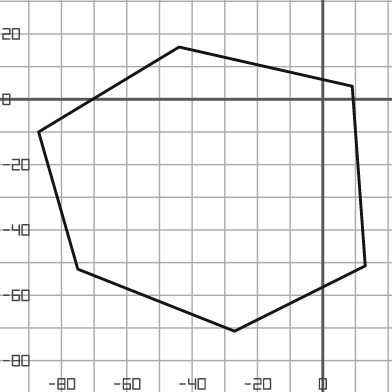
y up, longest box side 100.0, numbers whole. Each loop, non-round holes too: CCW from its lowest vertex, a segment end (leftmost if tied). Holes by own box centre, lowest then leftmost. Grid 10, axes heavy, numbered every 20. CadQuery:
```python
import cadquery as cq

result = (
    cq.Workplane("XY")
    .moveTo(-27.0, -71.0)
    .lineTo(13.0, -51.0)
    .lineTo(9.0, 4.0)
    .lineTo(-44.0, 16.0)
    .lineTo(-87.0, -10.0)
    .lineTo(-75.0, -52.0)
    .close()
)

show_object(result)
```